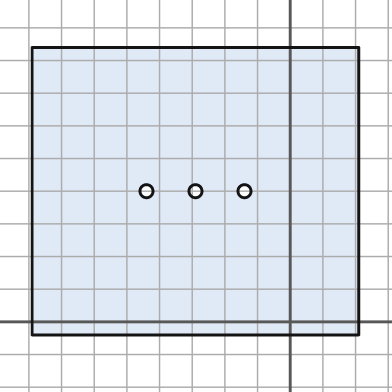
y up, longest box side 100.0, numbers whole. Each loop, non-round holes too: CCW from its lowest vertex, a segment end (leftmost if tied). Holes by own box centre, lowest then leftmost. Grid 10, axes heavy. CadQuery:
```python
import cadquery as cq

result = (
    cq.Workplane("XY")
    .moveTo(-79.0, -4.0)
    .lineTo(21.0, -4.0)
    .lineTo(21.0, 84.0)
    .lineTo(-79.0, 84.0)
    .close()
    .moveTo(-44.0, 40.0)
    .circle(2.0)
    .moveTo(-29.0, 40.0)
    .circle(2.0)
    .moveTo(-14.0, 40.0)
    .circle(2.0)
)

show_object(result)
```